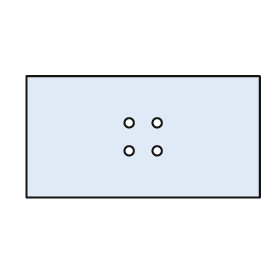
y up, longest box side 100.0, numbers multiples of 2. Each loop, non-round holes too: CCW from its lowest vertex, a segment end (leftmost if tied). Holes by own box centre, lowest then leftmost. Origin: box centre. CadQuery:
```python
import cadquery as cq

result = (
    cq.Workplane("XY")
    .moveTo(-50.0, -26.0)
    .lineTo(50.0, -26.0)
    .lineTo(50.0, 26.0)
    .lineTo(-50.0, 26.0)
    .close()
    .moveTo(-6.0, -6.0)
    .circle(2.0)
    .moveTo(6.0, -6.0)
    .circle(2.0)
    .moveTo(-6.0, 6.0)
    .circle(2.0)
    .moveTo(6.0, 6.0)
    .circle(2.0)
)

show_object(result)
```